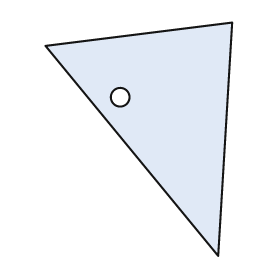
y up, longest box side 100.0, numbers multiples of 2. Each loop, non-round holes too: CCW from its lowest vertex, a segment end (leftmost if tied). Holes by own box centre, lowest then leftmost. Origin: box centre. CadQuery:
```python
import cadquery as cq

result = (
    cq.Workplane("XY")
    .moveTo(34.0, -50.0)
    .lineTo(40.0, 50.0)
    .lineTo(-40.0, 40.0)
    .close()
    .moveTo(-8.0, 18.0)
    .circle(4.0)
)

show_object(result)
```